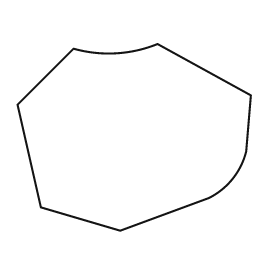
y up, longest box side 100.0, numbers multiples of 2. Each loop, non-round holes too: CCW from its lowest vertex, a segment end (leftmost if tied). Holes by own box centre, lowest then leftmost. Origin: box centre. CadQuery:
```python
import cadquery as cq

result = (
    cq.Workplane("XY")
    .moveTo(-6.0, -40.0)
    .lineTo(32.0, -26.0)
    .threePointArc((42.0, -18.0), (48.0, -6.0))
    .lineTo(50.0, 18.0)
    .lineTo(10.0, 40.0)
    .threePointArc((-8.0, 36.0), (-26.0, 38.0))
    .lineTo(-50.0, 14.0)
    .lineTo(-40.0, -30.0)
    .close()
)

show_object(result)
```